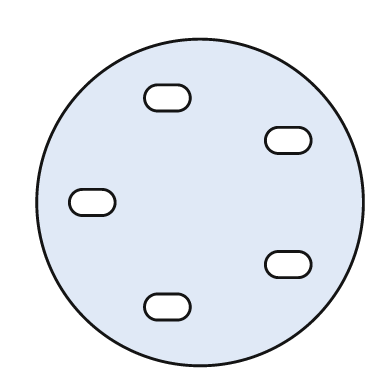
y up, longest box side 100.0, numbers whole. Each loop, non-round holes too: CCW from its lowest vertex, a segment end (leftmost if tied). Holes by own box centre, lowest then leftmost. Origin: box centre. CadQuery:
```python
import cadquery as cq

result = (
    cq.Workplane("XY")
    .moveTo(0.0, 0.0)
    .circle(50.0)
    .moveTo(-13.0, -36.0)
    .lineTo(-7.0, -36.0)
    .threePointArc((-3.0, -32.0), (-7.0, -28.0))
    .lineTo(-13.0, -28.0)
    .threePointArc((-17.0, -32.0), (-13.0, -36.0))
    .close()
    .moveTo(24.0, -23.0)
    .lineTo(30.0, -23.0)
    .threePointArc((34.0, -19.0), (30.0, -15.0))
    .lineTo(24.0, -15.0)
    .threePointArc((20.0, -19.0), (24.0, -23.0))
    .close()
    .moveTo(-36.0, -4.0)
    .lineTo(-30.0, -4.0)
    .threePointArc((-26.0, 0.0), (-30.0, 4.0))
    .lineTo(-36.0, 4.0)
    .threePointArc((-40.0, 0.0), (-36.0, -4.0))
    .close()
    .moveTo(24.0, 15.0)
    .lineTo(30.0, 15.0)
    .threePointArc((34.0, 19.0), (30.0, 23.0))
    .lineTo(24.0, 23.0)
    .threePointArc((20.0, 19.0), (24.0, 15.0))
    .close()
    .moveTo(-13.0, 28.0)
    .lineTo(-7.0, 28.0)
    .threePointArc((-3.0, 32.0), (-7.0, 36.0))
    .lineTo(-13.0, 36.0)
    .threePointArc((-17.0, 32.0), (-13.0, 28.0))
    .close()
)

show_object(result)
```